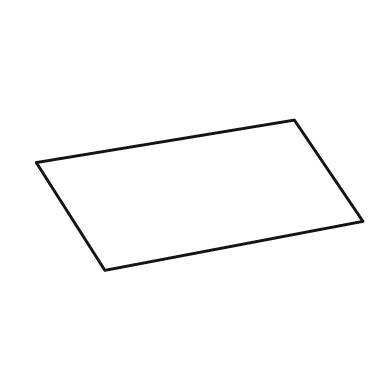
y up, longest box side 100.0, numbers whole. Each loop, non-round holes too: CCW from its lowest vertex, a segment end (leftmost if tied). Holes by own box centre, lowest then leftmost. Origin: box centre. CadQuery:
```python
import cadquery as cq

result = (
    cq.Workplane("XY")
    .moveTo(-29.0, -23.0)
    .lineTo(50.0, -8.0)
    .lineTo(29.0, 23.0)
    .lineTo(-50.0, 10.0)
    .close()
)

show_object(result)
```